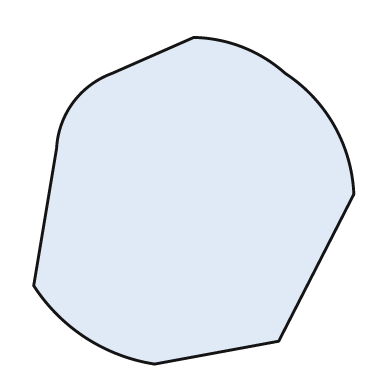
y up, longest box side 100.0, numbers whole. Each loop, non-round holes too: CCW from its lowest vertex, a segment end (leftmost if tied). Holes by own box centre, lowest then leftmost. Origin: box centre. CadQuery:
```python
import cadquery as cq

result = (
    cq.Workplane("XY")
    .moveTo(-12.0, -50.0)
    .lineTo(26.0, -43.0)
    .lineTo(49.0, 2.0)
    .threePointArc((43.0, 23.0), (28.0, 39.0))
    .threePointArc((15.0, 47.0), (0.0, 50.0))
    .lineTo(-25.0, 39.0)
    .threePointArc((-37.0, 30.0), (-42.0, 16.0))
    .lineTo(-49.0, -26.0)
    .threePointArc((-33.0, -42.0), (-12.0, -50.0))
    .close()
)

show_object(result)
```